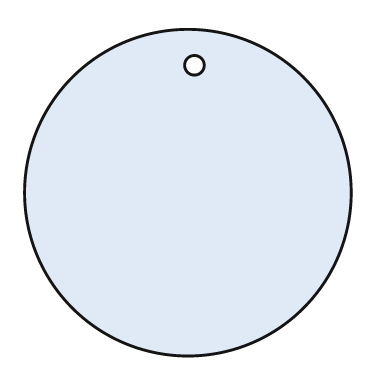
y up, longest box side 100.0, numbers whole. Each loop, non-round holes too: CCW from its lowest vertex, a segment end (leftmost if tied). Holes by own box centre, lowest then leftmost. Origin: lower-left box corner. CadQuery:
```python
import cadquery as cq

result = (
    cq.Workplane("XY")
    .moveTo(50.0, 50.0)
    .circle(50.0)
    .moveTo(52.0, 89.0)
    .circle(3.0)
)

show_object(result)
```